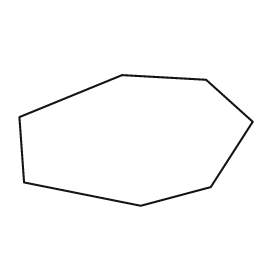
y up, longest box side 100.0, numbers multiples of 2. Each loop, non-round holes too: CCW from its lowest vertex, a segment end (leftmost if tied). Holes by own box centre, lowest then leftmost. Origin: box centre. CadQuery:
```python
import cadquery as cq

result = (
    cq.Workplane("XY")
    .moveTo(2.0, -28.0)
    .lineTo(32.0, -20.0)
    .lineTo(50.0, 8.0)
    .lineTo(30.0, 26.0)
    .lineTo(-6.0, 28.0)
    .lineTo(-50.0, 10.0)
    .lineTo(-48.0, -18.0)
    .close()
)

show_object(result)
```